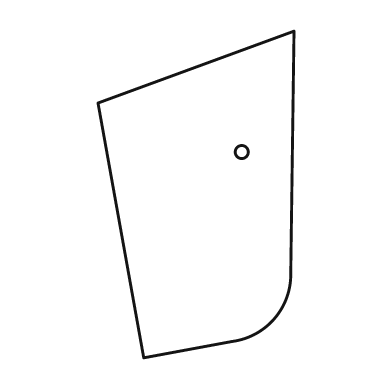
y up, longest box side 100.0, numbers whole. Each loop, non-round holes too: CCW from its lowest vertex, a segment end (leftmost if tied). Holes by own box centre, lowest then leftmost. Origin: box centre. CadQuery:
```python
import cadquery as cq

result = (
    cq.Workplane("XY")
    .moveTo(-16.0, -50.0)
    .lineTo(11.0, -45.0)
    .threePointArc((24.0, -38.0), (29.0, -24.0))
    .lineTo(30.0, 50.0)
    .lineTo(-30.0, 28.0)
    .close()
    .moveTo(14.0, 13.0)
    .circle(2.0)
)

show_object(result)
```